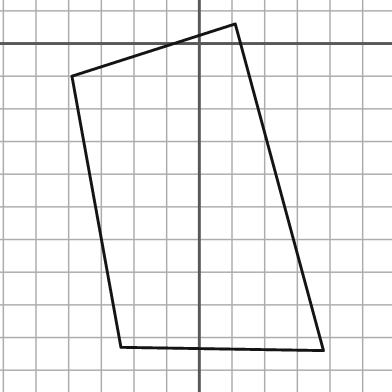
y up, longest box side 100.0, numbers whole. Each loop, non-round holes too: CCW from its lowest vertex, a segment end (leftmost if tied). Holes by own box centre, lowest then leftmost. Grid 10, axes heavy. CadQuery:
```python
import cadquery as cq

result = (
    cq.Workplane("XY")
    .moveTo(38.0, -94.0)
    .lineTo(11.0, 6.0)
    .lineTo(-39.0, -10.0)
    .lineTo(-24.0, -93.0)
    .close()
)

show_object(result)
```